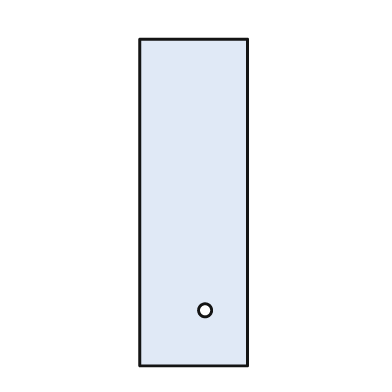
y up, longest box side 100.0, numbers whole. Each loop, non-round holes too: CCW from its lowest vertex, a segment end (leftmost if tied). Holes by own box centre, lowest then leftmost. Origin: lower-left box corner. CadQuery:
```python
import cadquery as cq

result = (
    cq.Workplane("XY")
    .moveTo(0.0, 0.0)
    .lineTo(33.0, 0.0)
    .lineTo(33.0, 100.0)
    .lineTo(0.0, 100.0)
    .close()
    .moveTo(20.0, 17.0)
    .circle(2.0)
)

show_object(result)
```